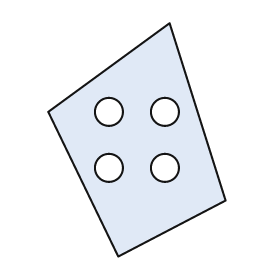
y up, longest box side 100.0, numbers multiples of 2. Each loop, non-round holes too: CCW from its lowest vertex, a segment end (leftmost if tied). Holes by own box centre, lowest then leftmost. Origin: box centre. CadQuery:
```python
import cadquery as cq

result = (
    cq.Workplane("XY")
    .moveTo(-8.0, -50.0)
    .lineTo(38.0, -26.0)
    .lineTo(14.0, 50.0)
    .lineTo(-38.0, 12.0)
    .close()
    .moveTo(-12.0, -12.0)
    .circle(6.0)
    .moveTo(12.0, -12.0)
    .circle(6.0)
    .moveTo(-12.0, 12.0)
    .circle(6.0)
    .moveTo(12.0, 12.0)
    .circle(6.0)
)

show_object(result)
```